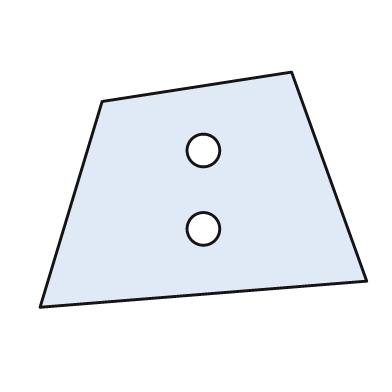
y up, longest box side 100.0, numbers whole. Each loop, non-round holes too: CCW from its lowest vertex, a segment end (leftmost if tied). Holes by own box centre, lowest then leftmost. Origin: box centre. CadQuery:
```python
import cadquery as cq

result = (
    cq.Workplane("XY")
    .moveTo(-50.0, -36.0)
    .lineTo(50.0, -28.0)
    .lineTo(27.0, 36.0)
    .lineTo(-31.0, 27.0)
    .close()
    .moveTo(0.0, -12.0)
    .circle(5.0)
    .moveTo(0.0, 12.0)
    .circle(5.0)
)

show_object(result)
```